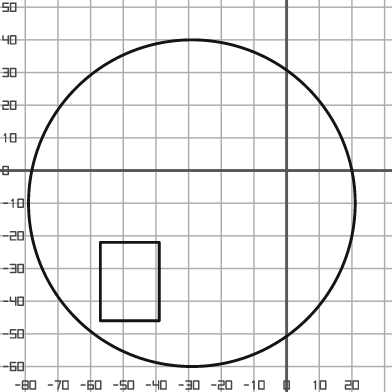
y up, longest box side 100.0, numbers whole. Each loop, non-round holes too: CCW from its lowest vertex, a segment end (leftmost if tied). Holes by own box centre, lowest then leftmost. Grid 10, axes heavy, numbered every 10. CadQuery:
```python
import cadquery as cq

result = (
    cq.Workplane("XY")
    .moveTo(-29.0, -10.0)
    .circle(50.0)
    .moveTo(-57.0, -46.0)
    .lineTo(-39.0, -46.0)
    .lineTo(-39.0, -22.0)
    .lineTo(-57.0, -22.0)
    .close()
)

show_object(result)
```